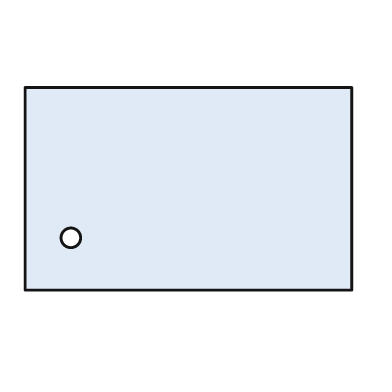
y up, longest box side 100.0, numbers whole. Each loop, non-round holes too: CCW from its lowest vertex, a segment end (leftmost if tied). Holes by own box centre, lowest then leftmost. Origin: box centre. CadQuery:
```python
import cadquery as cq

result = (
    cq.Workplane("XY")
    .moveTo(-50.0, -31.0)
    .lineTo(50.0, -31.0)
    .lineTo(50.0, 31.0)
    .lineTo(-50.0, 31.0)
    .close()
    .moveTo(-36.0, -15.0)
    .circle(3.0)
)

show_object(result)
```